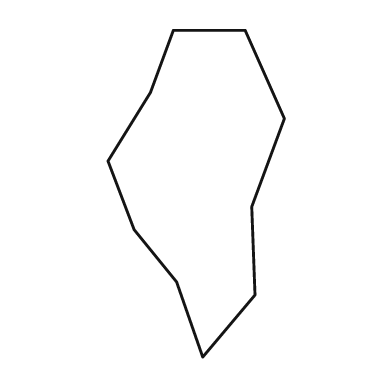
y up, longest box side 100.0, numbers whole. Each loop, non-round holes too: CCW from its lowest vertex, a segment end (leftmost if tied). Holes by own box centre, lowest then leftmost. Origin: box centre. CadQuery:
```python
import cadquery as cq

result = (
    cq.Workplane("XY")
    .moveTo(2.0, -50.0)
    .lineTo(18.0, -31.0)
    .lineTo(17.0, -4.0)
    .lineTo(27.0, 23.0)
    .lineTo(15.0, 50.0)
    .lineTo(-7.0, 50.0)
    .lineTo(-14.0, 31.0)
    .lineTo(-27.0, 10.0)
    .lineTo(-19.0, -11.0)
    .lineTo(-6.0, -27.0)
    .close()
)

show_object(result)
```